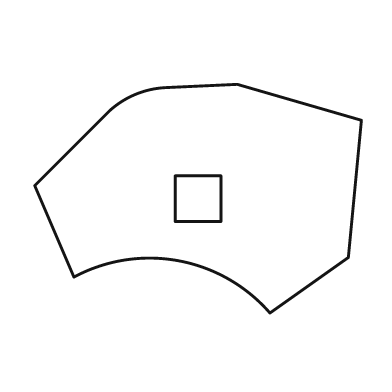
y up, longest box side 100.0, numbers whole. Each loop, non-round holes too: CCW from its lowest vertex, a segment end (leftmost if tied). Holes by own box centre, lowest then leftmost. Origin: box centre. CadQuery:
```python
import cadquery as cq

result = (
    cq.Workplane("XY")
    .moveTo(22.0, -35.0)
    .lineTo(46.0, -18.0)
    .lineTo(50.0, 24.0)
    .lineTo(12.0, 35.0)
    .lineTo(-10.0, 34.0)
    .threePointArc((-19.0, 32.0), (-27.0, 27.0))
    .lineTo(-50.0, 4.0)
    .lineTo(-38.0, -24.0)
    .threePointArc((-6.0, -19.0), (22.0, -35.0))
    .close()
    .moveTo(-7.0, -7.0)
    .lineTo(7.0, -7.0)
    .lineTo(7.0, 7.0)
    .lineTo(-7.0, 7.0)
    .close()
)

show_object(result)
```